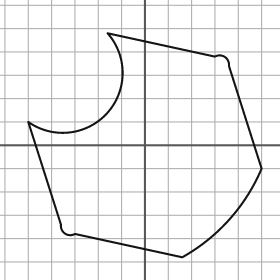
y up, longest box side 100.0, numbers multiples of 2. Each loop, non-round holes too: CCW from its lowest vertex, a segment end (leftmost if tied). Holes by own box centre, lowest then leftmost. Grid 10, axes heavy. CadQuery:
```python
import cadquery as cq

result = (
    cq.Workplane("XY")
    .moveTo(16.0, -48.0)
    .threePointArc((36.0, -32.0), (50.0, -10.0))
    .lineTo(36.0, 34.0)
    .threePointArc((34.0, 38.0), (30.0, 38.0))
    .lineTo(-16.0, 48.0)
    .threePointArc((-16.0, 14.0), (-50.0, 10.0))
    .lineTo(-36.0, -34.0)
    .threePointArc((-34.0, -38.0), (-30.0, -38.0))
    .close()
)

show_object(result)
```